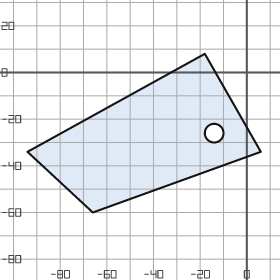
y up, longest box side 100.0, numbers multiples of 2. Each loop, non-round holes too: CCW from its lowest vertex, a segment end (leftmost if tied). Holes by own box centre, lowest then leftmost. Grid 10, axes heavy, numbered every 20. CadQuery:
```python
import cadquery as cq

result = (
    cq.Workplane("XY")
    .moveTo(-66.0, -60.0)
    .lineTo(6.0, -34.0)
    .lineTo(-18.0, 8.0)
    .lineTo(-94.0, -34.0)
    .close()
    .moveTo(-14.0, -26.0)
    .circle(4.0)
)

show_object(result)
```